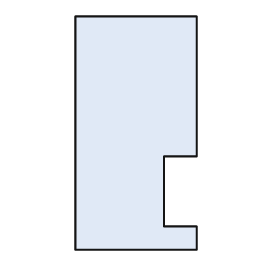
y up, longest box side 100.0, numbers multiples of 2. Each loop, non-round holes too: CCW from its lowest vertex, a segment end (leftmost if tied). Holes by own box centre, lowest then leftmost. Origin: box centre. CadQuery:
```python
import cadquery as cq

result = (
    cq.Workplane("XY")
    .moveTo(-26.0, -50.0)
    .lineTo(26.0, -50.0)
    .lineTo(26.0, -40.0)
    .lineTo(12.0, -40.0)
    .lineTo(12.0, -10.0)
    .lineTo(26.0, -10.0)
    .lineTo(26.0, 50.0)
    .lineTo(-26.0, 50.0)
    .close()
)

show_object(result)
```